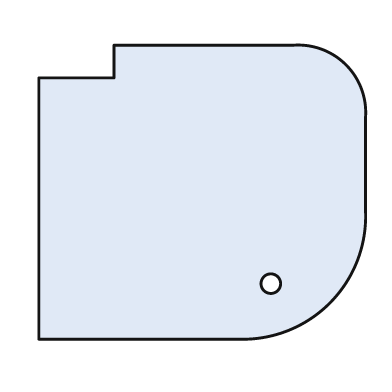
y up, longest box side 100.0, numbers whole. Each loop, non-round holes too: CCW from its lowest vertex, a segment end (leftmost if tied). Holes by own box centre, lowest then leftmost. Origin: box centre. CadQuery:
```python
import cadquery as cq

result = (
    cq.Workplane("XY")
    .moveTo(-50.0, -45.0)
    .lineTo(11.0, -45.0)
    .threePointArc((39.0, -34.0), (50.0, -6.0))
    .lineTo(50.0, 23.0)
    .threePointArc((44.0, 39.0), (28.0, 45.0))
    .lineTo(-27.0, 45.0)
    .lineTo(-27.0, 35.0)
    .lineTo(-50.0, 35.0)
    .close()
    .moveTo(21.0, -28.0)
    .circle(3.0)
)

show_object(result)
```